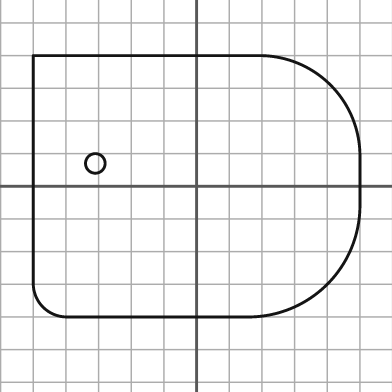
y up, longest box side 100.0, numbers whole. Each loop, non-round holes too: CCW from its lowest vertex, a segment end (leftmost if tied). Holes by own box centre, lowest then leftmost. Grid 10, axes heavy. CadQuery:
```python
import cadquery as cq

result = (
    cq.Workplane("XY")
    .moveTo(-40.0, -40.0)
    .lineTo(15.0, -40.0)
    .threePointArc((40.0, -30.0), (50.0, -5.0))
    .lineTo(50.0, 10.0)
    .threePointArc((41.0, 31.0), (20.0, 40.0))
    .lineTo(-50.0, 40.0)
    .lineTo(-50.0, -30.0)
    .threePointArc((-47.0, -37.0), (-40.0, -40.0))
    .close()
    .moveTo(-31.0, 7.0)
    .circle(3.0)
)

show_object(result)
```